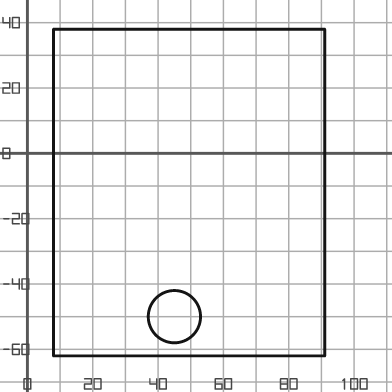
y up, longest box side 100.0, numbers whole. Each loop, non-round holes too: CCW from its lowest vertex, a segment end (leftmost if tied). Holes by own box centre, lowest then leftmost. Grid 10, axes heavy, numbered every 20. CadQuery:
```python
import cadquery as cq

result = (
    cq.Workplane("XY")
    .moveTo(8.0, -62.0)
    .lineTo(91.0, -62.0)
    .lineTo(91.0, 38.0)
    .lineTo(8.0, 38.0)
    .close()
    .moveTo(45.0, -50.0)
    .circle(8.0)
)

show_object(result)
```